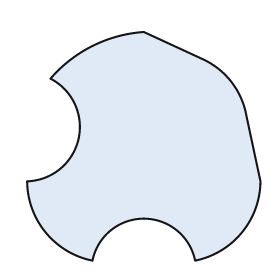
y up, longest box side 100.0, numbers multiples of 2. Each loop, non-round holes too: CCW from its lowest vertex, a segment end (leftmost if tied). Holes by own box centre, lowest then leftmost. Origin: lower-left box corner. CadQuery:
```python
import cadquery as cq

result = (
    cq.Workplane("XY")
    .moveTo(28.0, 0.0)
    .threePointArc((50.0, 18.0), (72.0, 0.0))
    .threePointArc((92.0, 12.0), (100.0, 34.0))
    .lineTo(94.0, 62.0)
    .threePointArc((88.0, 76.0), (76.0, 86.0))
    .lineTo(50.0, 98.0)
    .threePointArc((28.0, 92.0), (10.0, 78.0))
    .threePointArc((22.0, 52.0), (0.0, 34.0))
    .threePointArc((8.0, 12.0), (28.0, 0.0))
    .close()
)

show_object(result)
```